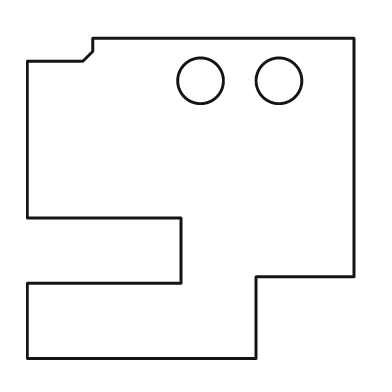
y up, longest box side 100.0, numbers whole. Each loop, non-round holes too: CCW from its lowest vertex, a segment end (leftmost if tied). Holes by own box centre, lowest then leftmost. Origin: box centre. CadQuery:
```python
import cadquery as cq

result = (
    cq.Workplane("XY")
    .moveTo(-50.0, -49.0)
    .lineTo(20.0, -49.0)
    .lineTo(20.0, -24.0)
    .lineTo(50.0, -24.0)
    .lineTo(50.0, 49.0)
    .lineTo(-30.0, 49.0)
    .lineTo(-30.0, 45.0)
    .lineTo(-33.0, 42.0)
    .lineTo(-50.0, 42.0)
    .lineTo(-50.0, -6.0)
    .lineTo(-3.0, -6.0)
    .lineTo(-3.0, -26.0)
    .lineTo(-50.0, -26.0)
    .close()
    .moveTo(3.0, 36.0)
    .circle(7.0)
    .moveTo(27.0, 36.0)
    .circle(7.0)
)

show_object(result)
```